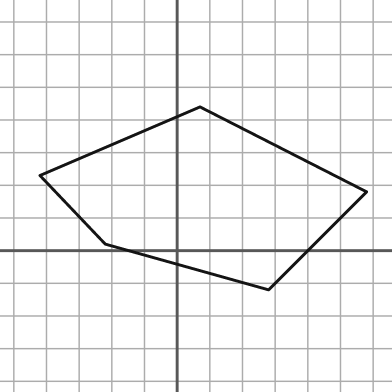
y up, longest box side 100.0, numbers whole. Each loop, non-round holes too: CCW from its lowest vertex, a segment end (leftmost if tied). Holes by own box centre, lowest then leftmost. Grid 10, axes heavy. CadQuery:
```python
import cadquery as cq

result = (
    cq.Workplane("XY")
    .moveTo(28.0, -12.0)
    .lineTo(58.0, 18.0)
    .lineTo(7.0, 44.0)
    .lineTo(-42.0, 23.0)
    .lineTo(-22.0, 2.0)
    .close()
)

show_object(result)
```